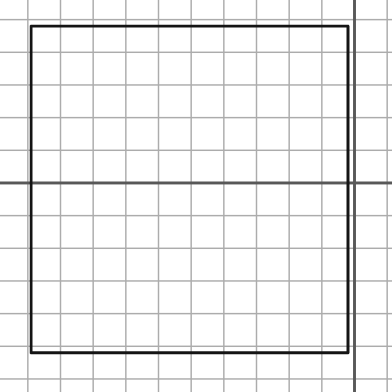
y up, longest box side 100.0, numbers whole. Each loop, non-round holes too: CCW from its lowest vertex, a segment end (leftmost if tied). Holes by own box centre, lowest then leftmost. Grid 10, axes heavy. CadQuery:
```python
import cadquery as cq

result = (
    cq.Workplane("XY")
    .moveTo(-99.0, -52.0)
    .lineTo(-2.0, -52.0)
    .lineTo(-2.0, 48.0)
    .lineTo(-99.0, 48.0)
    .close()
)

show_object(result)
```